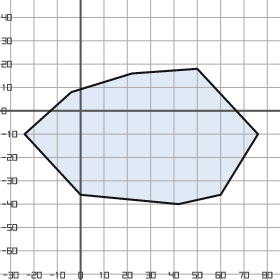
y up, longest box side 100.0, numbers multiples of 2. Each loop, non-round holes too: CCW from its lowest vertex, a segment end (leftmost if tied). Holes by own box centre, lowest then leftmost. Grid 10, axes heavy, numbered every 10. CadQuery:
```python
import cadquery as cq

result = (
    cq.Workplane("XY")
    .moveTo(42.0, -40.0)
    .lineTo(60.0, -36.0)
    .lineTo(76.0, -10.0)
    .lineTo(50.0, 18.0)
    .lineTo(22.0, 16.0)
    .lineTo(-4.0, 8.0)
    .lineTo(-24.0, -10.0)
    .lineTo(0.0, -36.0)
    .close()
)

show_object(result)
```